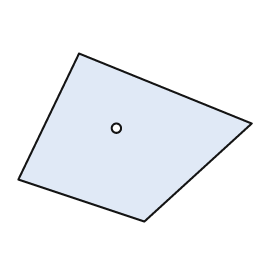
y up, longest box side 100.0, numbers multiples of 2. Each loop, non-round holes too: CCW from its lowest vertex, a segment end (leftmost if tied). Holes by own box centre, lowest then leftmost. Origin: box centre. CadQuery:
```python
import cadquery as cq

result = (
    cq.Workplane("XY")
    .moveTo(4.0, -36.0)
    .lineTo(50.0, 6.0)
    .lineTo(-24.0, 36.0)
    .lineTo(-50.0, -18.0)
    .close()
    .moveTo(-8.0, 4.0)
    .circle(2.0)
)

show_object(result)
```